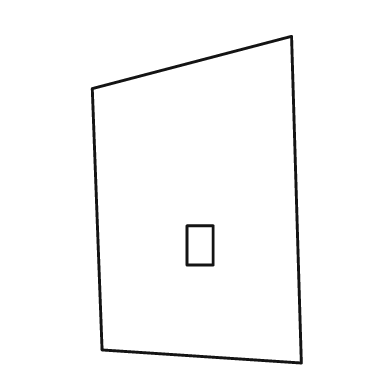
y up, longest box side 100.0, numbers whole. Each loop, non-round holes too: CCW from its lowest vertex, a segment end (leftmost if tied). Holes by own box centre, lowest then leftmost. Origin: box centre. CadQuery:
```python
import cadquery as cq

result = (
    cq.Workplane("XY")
    .moveTo(32.0, -50.0)
    .lineTo(29.0, 50.0)
    .lineTo(-32.0, 34.0)
    .lineTo(-29.0, -46.0)
    .close()
    .moveTo(-3.0, -20.0)
    .lineTo(5.0, -20.0)
    .lineTo(5.0, -8.0)
    .lineTo(-3.0, -8.0)
    .close()
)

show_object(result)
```